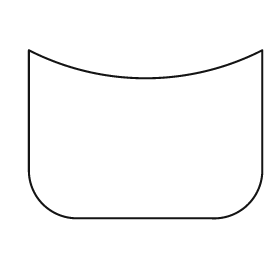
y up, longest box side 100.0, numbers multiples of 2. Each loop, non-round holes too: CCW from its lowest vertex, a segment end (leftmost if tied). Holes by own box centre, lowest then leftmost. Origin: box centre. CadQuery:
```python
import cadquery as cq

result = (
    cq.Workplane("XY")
    .moveTo(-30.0, -36.0)
    .lineTo(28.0, -36.0)
    .threePointArc((44.0, -30.0), (50.0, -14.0))
    .lineTo(50.0, 36.0)
    .threePointArc((0.0, 24.0), (-50.0, 36.0))
    .lineTo(-50.0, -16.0)
    .threePointArc((-44.0, -30.0), (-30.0, -36.0))
    .close()
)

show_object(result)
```